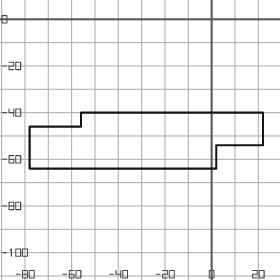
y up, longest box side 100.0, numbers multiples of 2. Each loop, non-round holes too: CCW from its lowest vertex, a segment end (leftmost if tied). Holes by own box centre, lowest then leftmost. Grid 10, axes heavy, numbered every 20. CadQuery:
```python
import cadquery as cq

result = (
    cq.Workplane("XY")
    .moveTo(-78.0, -64.0)
    .lineTo(2.0, -64.0)
    .lineTo(2.0, -54.0)
    .lineTo(22.0, -54.0)
    .lineTo(22.0, -40.0)
    .lineTo(-56.0, -40.0)
    .lineTo(-56.0, -46.0)
    .lineTo(-78.0, -46.0)
    .close()
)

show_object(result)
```